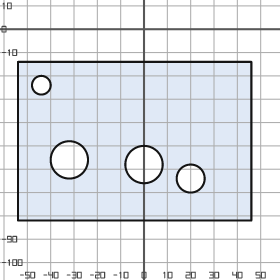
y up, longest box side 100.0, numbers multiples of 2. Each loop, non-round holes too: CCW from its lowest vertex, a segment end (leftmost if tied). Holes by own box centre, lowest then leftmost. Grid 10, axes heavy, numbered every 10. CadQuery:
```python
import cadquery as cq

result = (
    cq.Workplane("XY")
    .moveTo(-54.0, -82.0)
    .lineTo(46.0, -82.0)
    .lineTo(46.0, -14.0)
    .lineTo(-54.0, -14.0)
    .close()
    .moveTo(20.0, -64.0)
    .circle(6.0)
    .moveTo(0.0, -58.0)
    .circle(8.0)
    .moveTo(-32.0, -56.0)
    .circle(8.0)
    .moveTo(-44.0, -24.0)
    .circle(4.0)
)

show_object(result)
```